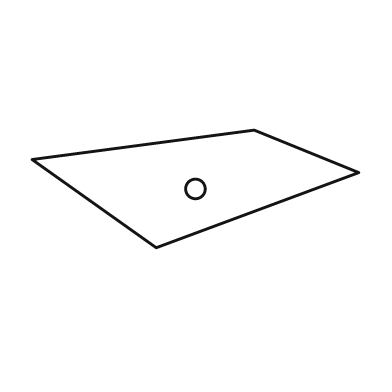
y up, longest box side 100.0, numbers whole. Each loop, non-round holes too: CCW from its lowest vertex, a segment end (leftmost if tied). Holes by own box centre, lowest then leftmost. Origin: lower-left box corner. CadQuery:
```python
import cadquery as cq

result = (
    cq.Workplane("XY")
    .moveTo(38.0, 0.0)
    .lineTo(100.0, 23.0)
    .lineTo(68.0, 36.0)
    .lineTo(0.0, 27.0)
    .close()
    .moveTo(50.0, 18.0)
    .circle(3.0)
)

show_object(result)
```